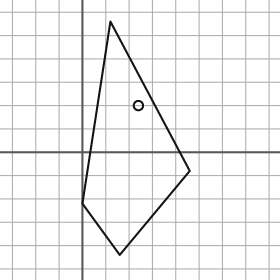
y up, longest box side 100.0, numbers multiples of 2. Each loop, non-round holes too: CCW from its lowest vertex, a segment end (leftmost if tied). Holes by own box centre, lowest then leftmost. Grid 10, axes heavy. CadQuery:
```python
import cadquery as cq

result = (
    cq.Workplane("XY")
    .moveTo(16.0, -44.0)
    .lineTo(46.0, -8.0)
    .lineTo(12.0, 56.0)
    .lineTo(0.0, -22.0)
    .close()
    .moveTo(24.0, 20.0)
    .circle(2.0)
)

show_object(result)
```